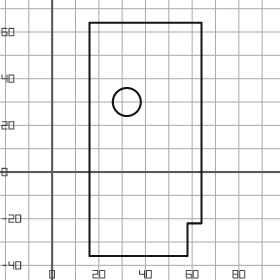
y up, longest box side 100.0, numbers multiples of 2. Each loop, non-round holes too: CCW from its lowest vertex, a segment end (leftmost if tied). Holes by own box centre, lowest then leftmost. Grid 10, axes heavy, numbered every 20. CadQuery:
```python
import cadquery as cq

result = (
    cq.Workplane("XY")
    .moveTo(16.0, -36.0)
    .lineTo(58.0, -36.0)
    .lineTo(58.0, -22.0)
    .lineTo(64.0, -22.0)
    .lineTo(64.0, 64.0)
    .lineTo(16.0, 64.0)
    .close()
    .moveTo(32.0, 30.0)
    .circle(6.0)
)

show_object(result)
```